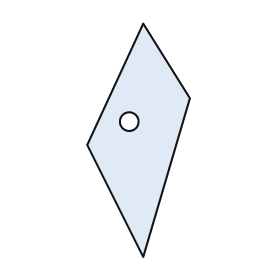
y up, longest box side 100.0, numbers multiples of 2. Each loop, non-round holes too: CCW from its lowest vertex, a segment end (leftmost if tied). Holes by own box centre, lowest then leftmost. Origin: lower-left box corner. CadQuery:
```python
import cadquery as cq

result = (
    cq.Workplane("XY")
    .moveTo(24.0, 0.0)
    .lineTo(44.0, 68.0)
    .lineTo(24.0, 100.0)
    .lineTo(0.0, 48.0)
    .close()
    .moveTo(18.0, 58.0)
    .circle(4.0)
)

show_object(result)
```